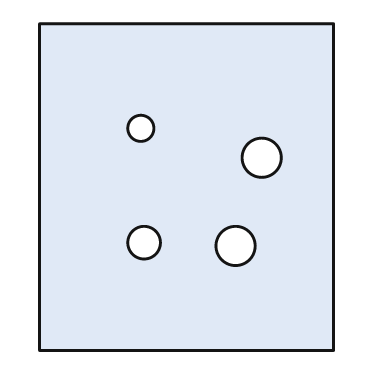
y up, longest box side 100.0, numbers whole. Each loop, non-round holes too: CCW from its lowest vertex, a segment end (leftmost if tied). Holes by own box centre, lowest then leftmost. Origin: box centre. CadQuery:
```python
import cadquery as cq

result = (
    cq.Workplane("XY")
    .moveTo(-45.0, -50.0)
    .lineTo(45.0, -50.0)
    .lineTo(45.0, 50.0)
    .lineTo(-45.0, 50.0)
    .close()
    .moveTo(15.0, -18.0)
    .circle(6.0)
    .moveTo(-13.0, -17.0)
    .circle(5.0)
    .moveTo(23.0, 9.0)
    .circle(6.0)
    .moveTo(-14.0, 18.0)
    .circle(4.0)
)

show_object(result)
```